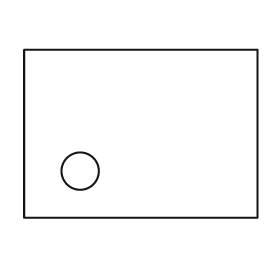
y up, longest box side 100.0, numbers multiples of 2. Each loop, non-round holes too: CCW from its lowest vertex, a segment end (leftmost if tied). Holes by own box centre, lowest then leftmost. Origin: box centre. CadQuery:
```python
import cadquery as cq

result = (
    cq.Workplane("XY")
    .moveTo(-50.0, -36.0)
    .lineTo(50.0, -36.0)
    .lineTo(50.0, 36.0)
    .lineTo(-50.0, 36.0)
    .close()
    .moveTo(-26.0, -16.0)
    .circle(8.0)
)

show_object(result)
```